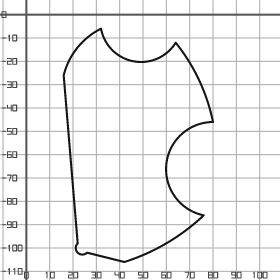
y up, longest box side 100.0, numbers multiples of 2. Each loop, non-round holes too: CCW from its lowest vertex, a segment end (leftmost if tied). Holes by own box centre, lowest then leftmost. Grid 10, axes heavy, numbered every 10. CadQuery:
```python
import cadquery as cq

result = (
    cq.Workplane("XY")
    .moveTo(42.0, -106.0)
    .threePointArc((60.0, -98.0), (76.0, -86.0))
    .threePointArc((60.0, -64.0), (80.0, -46.0))
    .threePointArc((74.0, -28.0), (64.0, -12.0))
    .threePointArc((46.0, -20.0), (32.0, -6.0))
    .threePointArc((22.0, -14.0), (16.0, -26.0))
    .lineTo(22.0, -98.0)
    .threePointArc((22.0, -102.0), (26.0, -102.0))
    .close()
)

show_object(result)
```